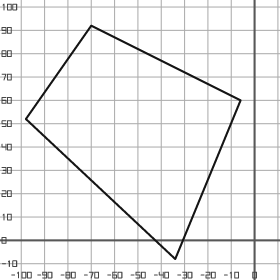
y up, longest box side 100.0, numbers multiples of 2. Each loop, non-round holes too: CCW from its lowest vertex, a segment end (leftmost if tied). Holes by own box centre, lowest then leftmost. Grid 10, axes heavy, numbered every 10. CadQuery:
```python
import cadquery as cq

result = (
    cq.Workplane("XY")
    .moveTo(-34.0, -8.0)
    .lineTo(-6.0, 60.0)
    .lineTo(-70.0, 92.0)
    .lineTo(-98.0, 52.0)
    .close()
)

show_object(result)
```